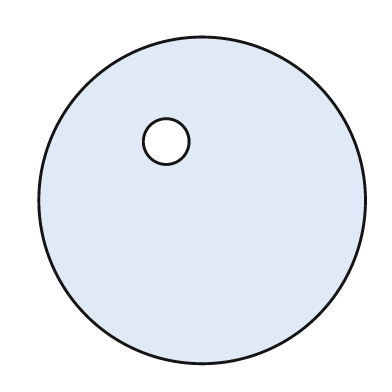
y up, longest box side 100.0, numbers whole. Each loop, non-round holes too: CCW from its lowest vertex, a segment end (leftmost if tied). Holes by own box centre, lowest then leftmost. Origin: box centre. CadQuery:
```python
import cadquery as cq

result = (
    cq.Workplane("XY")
    .moveTo(0.0, 0.0)
    .circle(50.0)
    .moveTo(-11.0, 18.0)
    .circle(7.0)
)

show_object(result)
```